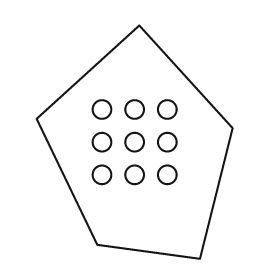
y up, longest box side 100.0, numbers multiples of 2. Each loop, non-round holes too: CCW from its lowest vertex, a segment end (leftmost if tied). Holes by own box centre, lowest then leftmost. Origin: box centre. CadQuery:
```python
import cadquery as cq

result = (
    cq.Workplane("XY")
    .moveTo(28.0, -50.0)
    .lineTo(42.0, 6.0)
    .lineTo(2.0, 50.0)
    .lineTo(-42.0, 10.0)
    .lineTo(-16.0, -44.0)
    .close()
    .moveTo(-14.0, -14.0)
    .circle(4.0)
    .moveTo(0.0, -14.0)
    .circle(4.0)
    .moveTo(14.0, -14.0)
    .circle(4.0)
    .moveTo(-14.0, 0.0)
    .circle(4.0)
    .moveTo(0.0, 0.0)
    .circle(4.0)
    .moveTo(14.0, 0.0)
    .circle(4.0)
    .moveTo(-14.0, 14.0)
    .circle(4.0)
    .moveTo(0.0, 14.0)
    .circle(4.0)
    .moveTo(14.0, 14.0)
    .circle(4.0)
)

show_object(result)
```